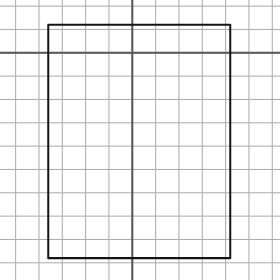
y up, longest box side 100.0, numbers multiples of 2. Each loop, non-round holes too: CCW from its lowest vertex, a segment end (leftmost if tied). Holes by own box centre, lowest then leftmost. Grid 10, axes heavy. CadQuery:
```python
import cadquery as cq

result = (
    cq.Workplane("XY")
    .moveTo(-36.0, -88.0)
    .lineTo(42.0, -88.0)
    .lineTo(42.0, 12.0)
    .lineTo(-36.0, 12.0)
    .close()
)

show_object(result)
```